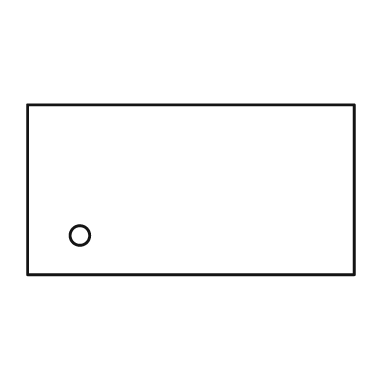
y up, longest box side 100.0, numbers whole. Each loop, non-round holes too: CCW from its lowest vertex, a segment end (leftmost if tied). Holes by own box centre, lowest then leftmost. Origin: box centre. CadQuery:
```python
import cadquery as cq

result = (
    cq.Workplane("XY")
    .moveTo(-50.0, -26.0)
    .lineTo(50.0, -26.0)
    .lineTo(50.0, 26.0)
    .lineTo(-50.0, 26.0)
    .close()
    .moveTo(-34.0, -14.0)
    .circle(3.0)
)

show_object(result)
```